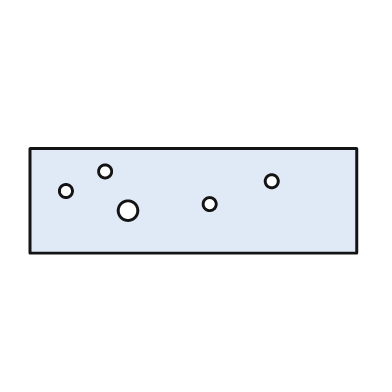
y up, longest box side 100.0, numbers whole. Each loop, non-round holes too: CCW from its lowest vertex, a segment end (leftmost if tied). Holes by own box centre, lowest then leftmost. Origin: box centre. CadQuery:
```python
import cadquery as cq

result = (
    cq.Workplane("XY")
    .moveTo(-50.0, -16.0)
    .lineTo(50.0, -16.0)
    .lineTo(50.0, 16.0)
    .lineTo(-50.0, 16.0)
    .close()
    .moveTo(-20.0, -3.0)
    .circle(3.0)
    .moveTo(5.0, -1.0)
    .circle(2.0)
    .moveTo(-39.0, 3.0)
    .circle(2.0)
    .moveTo(24.0, 6.0)
    .circle(2.0)
    .moveTo(-27.0, 9.0)
    .circle(2.0)
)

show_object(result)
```